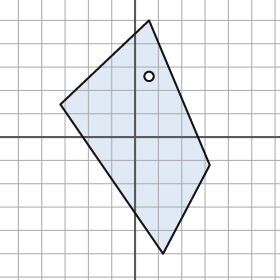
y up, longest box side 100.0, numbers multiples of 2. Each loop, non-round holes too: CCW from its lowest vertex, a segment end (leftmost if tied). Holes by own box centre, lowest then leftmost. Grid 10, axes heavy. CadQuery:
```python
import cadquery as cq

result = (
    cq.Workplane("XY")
    .moveTo(12.0, -50.0)
    .lineTo(32.0, -12.0)
    .lineTo(6.0, 50.0)
    .lineTo(-32.0, 14.0)
    .close()
    .moveTo(6.0, 26.0)
    .circle(2.0)
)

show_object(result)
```